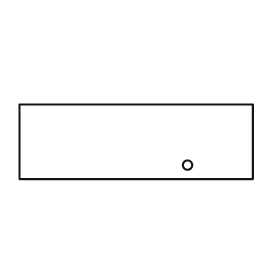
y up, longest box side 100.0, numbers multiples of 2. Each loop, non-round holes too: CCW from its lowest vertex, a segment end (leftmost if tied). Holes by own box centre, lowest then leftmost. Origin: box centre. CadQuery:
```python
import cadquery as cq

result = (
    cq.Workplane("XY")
    .moveTo(-50.0, -16.0)
    .lineTo(50.0, -16.0)
    .lineTo(50.0, 16.0)
    .lineTo(-50.0, 16.0)
    .close()
    .moveTo(22.0, -10.0)
    .circle(2.0)
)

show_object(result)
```